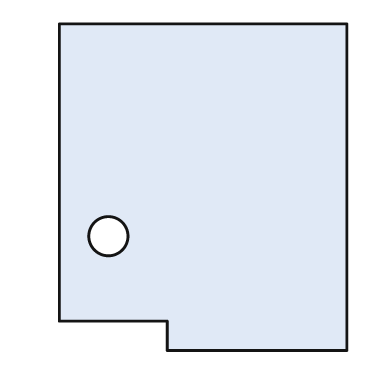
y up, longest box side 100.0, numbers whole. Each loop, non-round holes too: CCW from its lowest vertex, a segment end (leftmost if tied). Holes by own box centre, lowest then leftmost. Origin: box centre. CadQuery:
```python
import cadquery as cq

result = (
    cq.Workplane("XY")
    .moveTo(-11.0, -50.0)
    .lineTo(44.0, -50.0)
    .lineTo(44.0, 50.0)
    .lineTo(-44.0, 50.0)
    .lineTo(-44.0, -41.0)
    .lineTo(-11.0, -41.0)
    .close()
    .moveTo(-29.0, -15.0)
    .circle(6.0)
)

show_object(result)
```